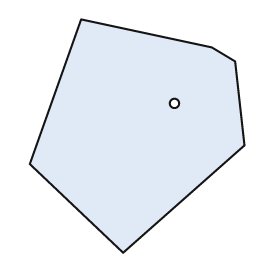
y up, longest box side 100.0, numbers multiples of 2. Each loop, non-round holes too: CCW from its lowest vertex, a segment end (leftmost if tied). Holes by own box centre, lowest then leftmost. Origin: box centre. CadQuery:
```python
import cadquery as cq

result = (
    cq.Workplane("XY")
    .moveTo(-6.0, -50.0)
    .lineTo(46.0, -4.0)
    .lineTo(42.0, 32.0)
    .lineTo(32.0, 38.0)
    .lineTo(-24.0, 50.0)
    .lineTo(-46.0, -12.0)
    .close()
    .moveTo(16.0, 14.0)
    .circle(2.0)
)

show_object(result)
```